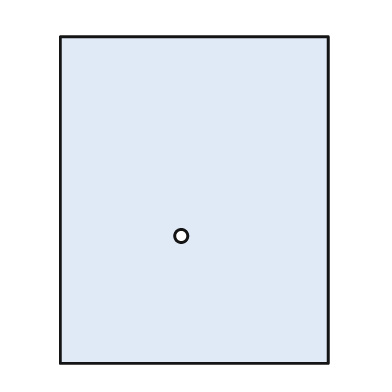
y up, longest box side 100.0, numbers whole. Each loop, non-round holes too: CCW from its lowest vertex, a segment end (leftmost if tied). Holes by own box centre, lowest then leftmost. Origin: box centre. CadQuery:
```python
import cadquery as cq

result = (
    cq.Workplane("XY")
    .moveTo(-41.0, -50.0)
    .lineTo(41.0, -50.0)
    .lineTo(41.0, 50.0)
    .lineTo(-41.0, 50.0)
    .close()
    .moveTo(-4.0, -11.0)
    .circle(2.0)
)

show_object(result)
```